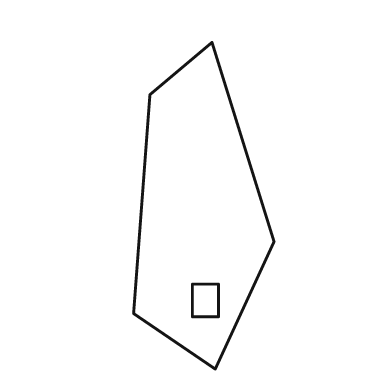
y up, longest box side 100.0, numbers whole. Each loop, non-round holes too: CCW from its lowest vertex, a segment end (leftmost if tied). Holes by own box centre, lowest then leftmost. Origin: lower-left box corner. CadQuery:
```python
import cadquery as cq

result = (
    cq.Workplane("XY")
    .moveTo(25.0, 0.0)
    .lineTo(43.0, 39.0)
    .lineTo(24.0, 100.0)
    .lineTo(5.0, 84.0)
    .lineTo(0.0, 17.0)
    .close()
    .moveTo(18.0, 16.0)
    .lineTo(26.0, 16.0)
    .lineTo(26.0, 26.0)
    .lineTo(18.0, 26.0)
    .close()
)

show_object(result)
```